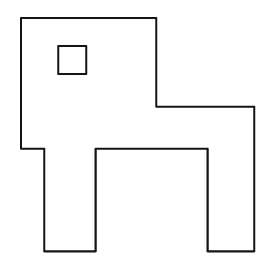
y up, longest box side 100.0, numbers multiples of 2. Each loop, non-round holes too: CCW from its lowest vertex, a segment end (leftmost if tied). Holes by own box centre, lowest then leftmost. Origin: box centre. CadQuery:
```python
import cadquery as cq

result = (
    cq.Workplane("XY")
    .moveTo(-40.0, -50.0)
    .lineTo(-18.0, -50.0)
    .lineTo(-18.0, -6.0)
    .lineTo(30.0, -6.0)
    .lineTo(30.0, -50.0)
    .lineTo(50.0, -50.0)
    .lineTo(50.0, 12.0)
    .lineTo(8.0, 12.0)
    .lineTo(8.0, 50.0)
    .lineTo(-50.0, 50.0)
    .lineTo(-50.0, -6.0)
    .lineTo(-40.0, -6.0)
    .close()
    .moveTo(-34.0, 26.0)
    .lineTo(-22.0, 26.0)
    .lineTo(-22.0, 38.0)
    .lineTo(-34.0, 38.0)
    .close()
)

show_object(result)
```